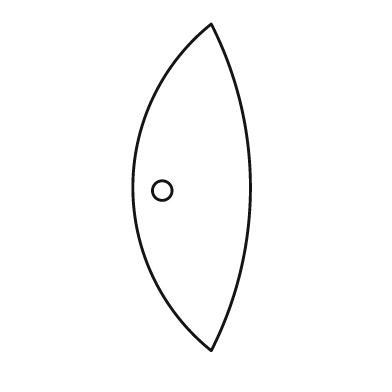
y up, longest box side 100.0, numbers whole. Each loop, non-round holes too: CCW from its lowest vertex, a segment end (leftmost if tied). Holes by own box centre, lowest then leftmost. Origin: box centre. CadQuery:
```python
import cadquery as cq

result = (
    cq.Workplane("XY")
    .moveTo(6.0, -50.0)
    .threePointArc((18.0, 0.0), (6.0, 50.0))
    .threePointArc((-18.0, 0.0), (6.0, -50.0))
    .close()
    .moveTo(-9.0, -1.0)
    .circle(3.0)
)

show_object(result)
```